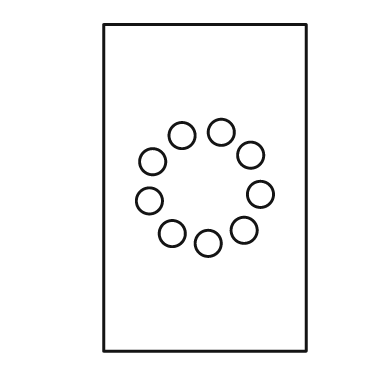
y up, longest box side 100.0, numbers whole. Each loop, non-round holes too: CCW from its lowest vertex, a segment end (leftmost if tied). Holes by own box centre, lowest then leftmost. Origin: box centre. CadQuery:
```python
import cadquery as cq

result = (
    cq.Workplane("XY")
    .moveTo(-31.0, -50.0)
    .lineTo(31.0, -50.0)
    .lineTo(31.0, 50.0)
    .lineTo(-31.0, 50.0)
    .close()
    .moveTo(1.0, -17.0)
    .circle(4.0)
    .moveTo(-10.0, -14.0)
    .circle(4.0)
    .moveTo(12.0, -13.0)
    .circle(4.0)
    .moveTo(-17.0, -4.0)
    .circle(4.0)
    .moveTo(17.0, -2.0)
    .circle(4.0)
    .moveTo(-16.0, 8.0)
    .circle(4.0)
    .moveTo(14.0, 10.0)
    .circle(4.0)
    .moveTo(-7.0, 16.0)
    .circle(4.0)
    .moveTo(5.0, 17.0)
    .circle(4.0)
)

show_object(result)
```